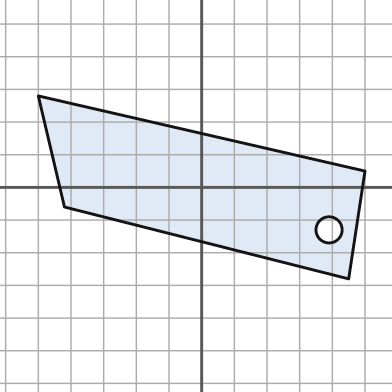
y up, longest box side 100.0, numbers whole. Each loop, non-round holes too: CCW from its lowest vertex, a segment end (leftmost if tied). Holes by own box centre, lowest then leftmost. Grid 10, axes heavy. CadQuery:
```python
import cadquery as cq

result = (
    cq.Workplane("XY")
    .moveTo(45.0, -28.0)
    .lineTo(50.0, 5.0)
    .lineTo(-50.0, 28.0)
    .lineTo(-42.0, -6.0)
    .close()
    .moveTo(39.0, -13.0)
    .circle(4.0)
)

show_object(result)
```